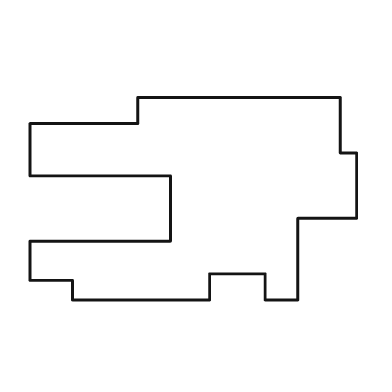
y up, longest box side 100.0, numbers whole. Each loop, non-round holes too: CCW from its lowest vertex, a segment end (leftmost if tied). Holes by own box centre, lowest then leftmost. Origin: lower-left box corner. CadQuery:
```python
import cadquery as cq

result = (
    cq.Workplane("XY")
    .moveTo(13.0, 0.0)
    .lineTo(55.0, 0.0)
    .lineTo(55.0, 8.0)
    .lineTo(72.0, 8.0)
    .lineTo(72.0, 0.0)
    .lineTo(82.0, 0.0)
    .lineTo(82.0, 25.0)
    .lineTo(100.0, 25.0)
    .lineTo(100.0, 45.0)
    .lineTo(95.0, 45.0)
    .lineTo(95.0, 62.0)
    .lineTo(33.0, 62.0)
    .lineTo(33.0, 54.0)
    .lineTo(0.0, 54.0)
    .lineTo(0.0, 38.0)
    .lineTo(43.0, 38.0)
    .lineTo(43.0, 18.0)
    .lineTo(0.0, 18.0)
    .lineTo(0.0, 6.0)
    .lineTo(13.0, 6.0)
    .close()
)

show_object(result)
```